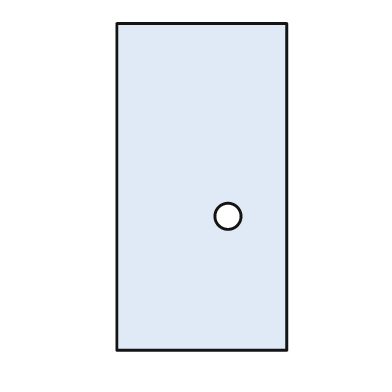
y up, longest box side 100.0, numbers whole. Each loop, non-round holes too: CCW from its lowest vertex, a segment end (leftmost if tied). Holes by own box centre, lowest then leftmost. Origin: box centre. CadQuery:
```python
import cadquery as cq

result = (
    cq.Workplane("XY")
    .moveTo(-26.0, -50.0)
    .lineTo(26.0, -50.0)
    .lineTo(26.0, 50.0)
    .lineTo(-26.0, 50.0)
    .close()
    .moveTo(8.0, -9.0)
    .circle(4.0)
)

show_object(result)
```